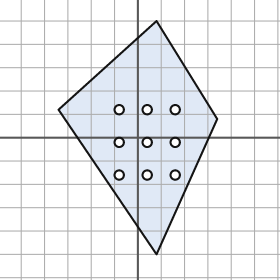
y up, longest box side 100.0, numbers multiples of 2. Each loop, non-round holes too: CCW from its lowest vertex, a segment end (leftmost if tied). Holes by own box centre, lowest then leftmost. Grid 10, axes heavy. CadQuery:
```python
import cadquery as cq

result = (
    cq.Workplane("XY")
    .moveTo(8.0, -50.0)
    .lineTo(34.0, 8.0)
    .lineTo(8.0, 50.0)
    .lineTo(-34.0, 12.0)
    .close()
    .moveTo(-8.0, -16.0)
    .circle(2.0)
    .moveTo(4.0, -16.0)
    .circle(2.0)
    .moveTo(16.0, -16.0)
    .circle(2.0)
    .moveTo(-8.0, -2.0)
    .circle(2.0)
    .moveTo(4.0, -2.0)
    .circle(2.0)
    .moveTo(16.0, -2.0)
    .circle(2.0)
    .moveTo(-8.0, 12.0)
    .circle(2.0)
    .moveTo(4.0, 12.0)
    .circle(2.0)
    .moveTo(16.0, 12.0)
    .circle(2.0)
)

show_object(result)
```